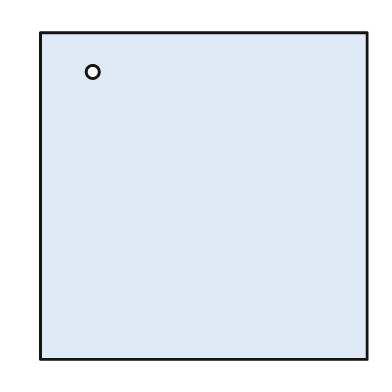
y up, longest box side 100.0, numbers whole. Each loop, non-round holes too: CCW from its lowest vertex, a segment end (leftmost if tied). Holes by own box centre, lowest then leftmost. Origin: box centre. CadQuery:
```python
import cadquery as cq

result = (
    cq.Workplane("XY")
    .moveTo(-50.0, -50.0)
    .lineTo(50.0, -50.0)
    .lineTo(50.0, 50.0)
    .lineTo(-50.0, 50.0)
    .close()
    .moveTo(-34.0, 38.0)
    .circle(2.0)
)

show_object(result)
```